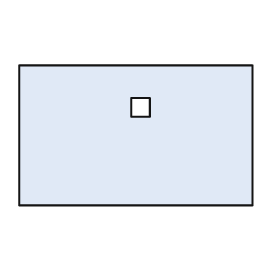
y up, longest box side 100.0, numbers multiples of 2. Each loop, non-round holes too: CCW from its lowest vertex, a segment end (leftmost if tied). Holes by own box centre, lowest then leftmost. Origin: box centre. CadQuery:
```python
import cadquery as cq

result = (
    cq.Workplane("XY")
    .moveTo(-50.0, -30.0)
    .lineTo(50.0, -30.0)
    .lineTo(50.0, 30.0)
    .lineTo(-50.0, 30.0)
    .close()
    .moveTo(-2.0, 8.0)
    .lineTo(6.0, 8.0)
    .lineTo(6.0, 16.0)
    .lineTo(-2.0, 16.0)
    .close()
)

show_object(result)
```